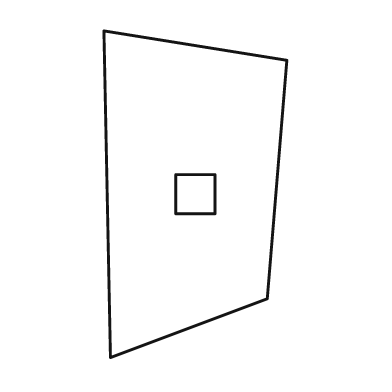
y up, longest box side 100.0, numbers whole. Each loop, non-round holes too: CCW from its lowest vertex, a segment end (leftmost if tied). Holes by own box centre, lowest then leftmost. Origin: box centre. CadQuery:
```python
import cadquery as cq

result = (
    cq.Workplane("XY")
    .moveTo(-26.0, -50.0)
    .lineTo(22.0, -32.0)
    .lineTo(28.0, 41.0)
    .lineTo(-28.0, 50.0)
    .close()
    .moveTo(-6.0, -6.0)
    .lineTo(6.0, -6.0)
    .lineTo(6.0, 6.0)
    .lineTo(-6.0, 6.0)
    .close()
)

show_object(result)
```